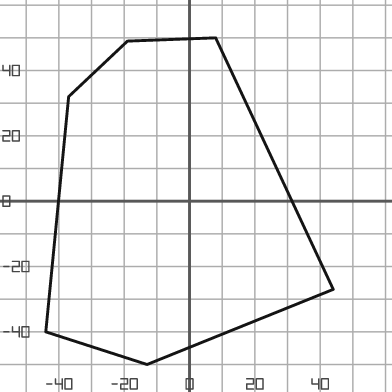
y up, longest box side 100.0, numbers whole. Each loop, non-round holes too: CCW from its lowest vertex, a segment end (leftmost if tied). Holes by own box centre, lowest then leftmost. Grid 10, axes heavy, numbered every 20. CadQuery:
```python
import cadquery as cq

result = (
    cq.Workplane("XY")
    .moveTo(-13.0, -50.0)
    .lineTo(44.0, -27.0)
    .lineTo(8.0, 50.0)
    .lineTo(-19.0, 49.0)
    .lineTo(-37.0, 32.0)
    .lineTo(-44.0, -40.0)
    .close()
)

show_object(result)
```